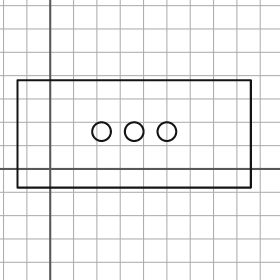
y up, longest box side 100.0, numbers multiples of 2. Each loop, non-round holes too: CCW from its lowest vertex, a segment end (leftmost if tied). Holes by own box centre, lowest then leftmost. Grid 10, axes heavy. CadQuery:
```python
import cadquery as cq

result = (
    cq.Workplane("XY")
    .moveTo(-14.0, -8.0)
    .lineTo(86.0, -8.0)
    .lineTo(86.0, 38.0)
    .lineTo(-14.0, 38.0)
    .close()
    .moveTo(22.0, 16.0)
    .circle(4.0)
    .moveTo(36.0, 16.0)
    .circle(4.0)
    .moveTo(50.0, 16.0)
    .circle(4.0)
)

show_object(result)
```